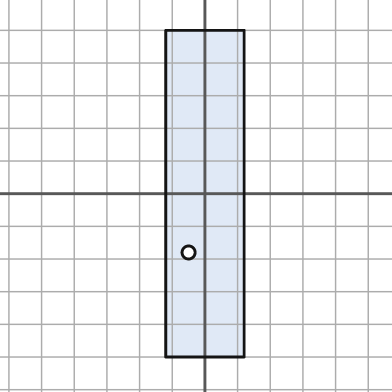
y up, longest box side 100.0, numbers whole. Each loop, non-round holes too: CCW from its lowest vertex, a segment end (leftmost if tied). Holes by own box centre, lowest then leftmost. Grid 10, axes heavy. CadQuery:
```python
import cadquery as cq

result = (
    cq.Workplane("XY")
    .moveTo(-12.0, -50.0)
    .lineTo(12.0, -50.0)
    .lineTo(12.0, 50.0)
    .lineTo(-12.0, 50.0)
    .close()
    .moveTo(-5.0, -18.0)
    .circle(2.0)
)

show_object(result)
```